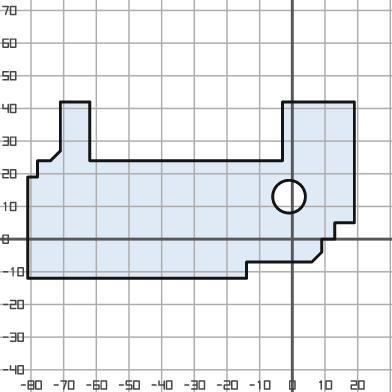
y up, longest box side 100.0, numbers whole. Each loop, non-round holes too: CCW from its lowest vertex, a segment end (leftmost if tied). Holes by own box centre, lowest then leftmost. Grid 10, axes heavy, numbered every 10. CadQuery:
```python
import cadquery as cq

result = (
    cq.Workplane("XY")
    .moveTo(-81.0, -12.0)
    .lineTo(-14.0, -12.0)
    .lineTo(-14.0, -7.0)
    .lineTo(6.0, -7.0)
    .lineTo(9.0, -4.0)
    .lineTo(9.0, 0.0)
    .lineTo(13.0, 0.0)
    .lineTo(13.0, 5.0)
    .lineTo(19.0, 5.0)
    .lineTo(19.0, 42.0)
    .lineTo(-3.0, 42.0)
    .lineTo(-3.0, 24.0)
    .lineTo(-62.0, 24.0)
    .lineTo(-62.0, 42.0)
    .lineTo(-71.0, 42.0)
    .lineTo(-71.0, 27.0)
    .lineTo(-74.0, 24.0)
    .lineTo(-78.0, 24.0)
    .lineTo(-78.0, 19.0)
    .lineTo(-81.0, 19.0)
    .close()
    .moveTo(-1.0, 13.0)
    .circle(5.0)
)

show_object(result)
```